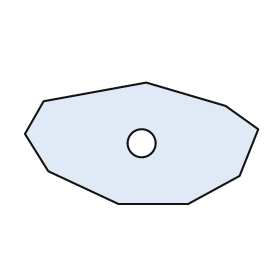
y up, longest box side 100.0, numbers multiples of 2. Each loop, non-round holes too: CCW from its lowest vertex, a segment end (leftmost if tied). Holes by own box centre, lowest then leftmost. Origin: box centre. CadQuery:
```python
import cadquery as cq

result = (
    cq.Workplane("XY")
    .moveTo(-10.0, -26.0)
    .lineTo(20.0, -26.0)
    .lineTo(42.0, -14.0)
    .lineTo(50.0, 6.0)
    .lineTo(36.0, 16.0)
    .lineTo(2.0, 26.0)
    .lineTo(-42.0, 18.0)
    .lineTo(-50.0, 4.0)
    .lineTo(-40.0, -12.0)
    .close()
    .moveTo(0.0, 0.0)
    .circle(6.0)
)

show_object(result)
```